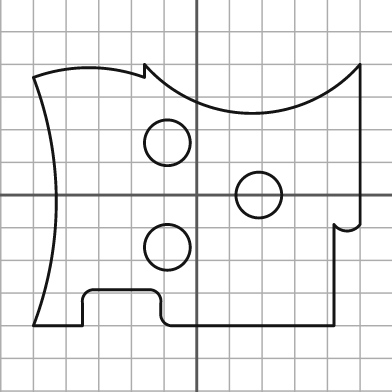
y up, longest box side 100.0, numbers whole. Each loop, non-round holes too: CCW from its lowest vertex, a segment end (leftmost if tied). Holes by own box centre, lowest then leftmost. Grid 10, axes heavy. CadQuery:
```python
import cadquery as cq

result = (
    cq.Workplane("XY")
    .moveTo(-50.0, -40.0)
    .lineTo(-35.0, -40.0)
    .lineTo(-35.0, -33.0)
    .threePointArc((-34.0, -30.0), (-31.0, -29.0))
    .lineTo(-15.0, -29.0)
    .threePointArc((-12.0, -30.0), (-11.0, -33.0))
    .lineTo(-11.0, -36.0)
    .threePointArc((-10.0, -39.0), (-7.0, -40.0))
    .lineTo(42.0, -40.0)
    .lineTo(42.0, -9.0)
    .threePointArc((46.0, -11.0), (50.0, -9.0))
    .lineTo(50.0, 40.0)
    .threePointArc((17.0, 25.0), (-16.0, 40.0))
    .lineTo(-16.0, 36.0)
    .threePointArc((-33.0, 39.0), (-50.0, 36.0))
    .threePointArc((-43.0, -2.0), (-50.0, -40.0))
    .close()
    .moveTo(-9.0, -16.0)
    .circle(7.0)
    .moveTo(19.0, 0.0)
    .circle(7.0)
    .moveTo(-9.0, 16.0)
    .circle(7.0)
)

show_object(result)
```